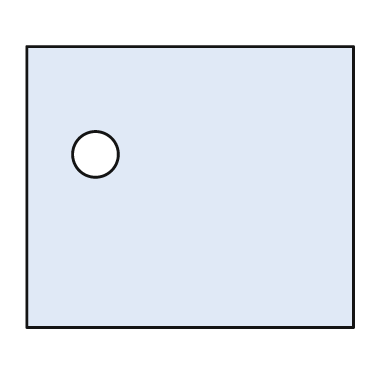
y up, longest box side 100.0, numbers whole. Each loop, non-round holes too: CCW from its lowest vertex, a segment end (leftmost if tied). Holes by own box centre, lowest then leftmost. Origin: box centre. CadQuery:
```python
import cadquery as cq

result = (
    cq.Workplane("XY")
    .moveTo(-50.0, -43.0)
    .lineTo(50.0, -43.0)
    .lineTo(50.0, 43.0)
    .lineTo(-50.0, 43.0)
    .close()
    .moveTo(-29.0, 10.0)
    .circle(7.0)
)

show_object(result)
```